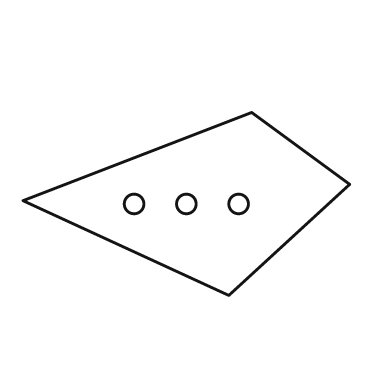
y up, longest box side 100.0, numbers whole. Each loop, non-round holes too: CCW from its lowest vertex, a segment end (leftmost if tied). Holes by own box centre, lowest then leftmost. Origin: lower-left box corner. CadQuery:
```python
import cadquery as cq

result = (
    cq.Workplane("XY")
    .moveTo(63.0, 0.0)
    .lineTo(100.0, 34.0)
    .lineTo(70.0, 56.0)
    .lineTo(0.0, 29.0)
    .close()
    .moveTo(34.0, 28.0)
    .circle(3.0)
    .moveTo(50.0, 28.0)
    .circle(3.0)
    .moveTo(66.0, 28.0)
    .circle(3.0)
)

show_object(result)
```